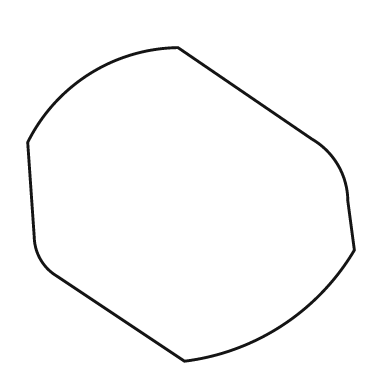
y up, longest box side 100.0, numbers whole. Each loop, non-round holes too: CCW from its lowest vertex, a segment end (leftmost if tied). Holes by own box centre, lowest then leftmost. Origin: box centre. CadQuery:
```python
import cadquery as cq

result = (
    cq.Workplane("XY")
    .moveTo(-2.0, -48.0)
    .threePointArc((28.0, -37.0), (50.0, -14.0))
    .lineTo(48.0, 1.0)
    .threePointArc((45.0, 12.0), (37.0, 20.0))
    .lineTo(-4.0, 48.0)
    .threePointArc((-31.0, 40.0), (-50.0, 19.0))
    .lineTo(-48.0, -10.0)
    .threePointArc((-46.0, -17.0), (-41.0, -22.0))
    .close()
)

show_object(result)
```